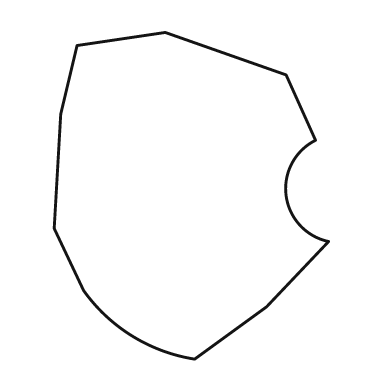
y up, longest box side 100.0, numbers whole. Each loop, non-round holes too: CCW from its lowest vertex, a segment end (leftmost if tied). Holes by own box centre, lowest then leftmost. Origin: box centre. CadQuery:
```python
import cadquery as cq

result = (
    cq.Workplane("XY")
    .moveTo(1.0, -50.0)
    .lineTo(23.0, -34.0)
    .lineTo(42.0, -14.0)
    .threePointArc((29.0, 0.0), (38.0, 17.0))
    .lineTo(29.0, 37.0)
    .lineTo(-8.0, 50.0)
    .lineTo(-35.0, 46.0)
    .lineTo(-40.0, 25.0)
    .lineTo(-42.0, -10.0)
    .lineTo(-33.0, -29.0)
    .threePointArc((-18.0, -43.0), (1.0, -50.0))
    .close()
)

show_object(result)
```